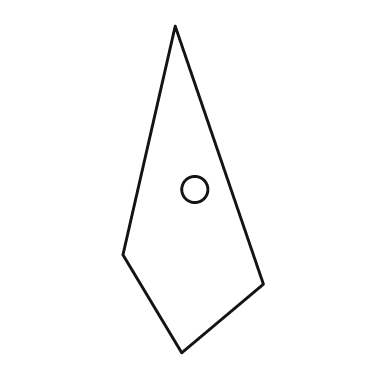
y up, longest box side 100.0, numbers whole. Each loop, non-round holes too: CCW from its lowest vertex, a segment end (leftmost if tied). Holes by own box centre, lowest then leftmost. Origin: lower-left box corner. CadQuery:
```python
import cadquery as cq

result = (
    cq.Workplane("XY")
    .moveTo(18.0, 0.0)
    .lineTo(43.0, 21.0)
    .lineTo(16.0, 100.0)
    .lineTo(0.0, 30.0)
    .close()
    .moveTo(22.0, 50.0)
    .circle(4.0)
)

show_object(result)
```